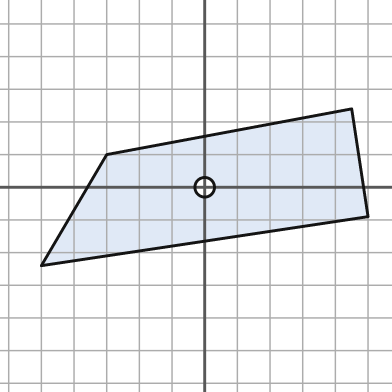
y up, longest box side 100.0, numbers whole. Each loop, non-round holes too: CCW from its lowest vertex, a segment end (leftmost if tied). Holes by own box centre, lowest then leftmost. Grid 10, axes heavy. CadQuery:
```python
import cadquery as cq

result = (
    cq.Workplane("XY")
    .moveTo(-50.0, -24.0)
    .lineTo(50.0, -9.0)
    .lineTo(45.0, 24.0)
    .lineTo(-30.0, 10.0)
    .close()
    .moveTo(0.0, 0.0)
    .circle(3.0)
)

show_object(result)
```